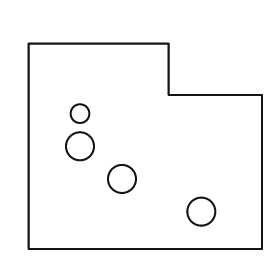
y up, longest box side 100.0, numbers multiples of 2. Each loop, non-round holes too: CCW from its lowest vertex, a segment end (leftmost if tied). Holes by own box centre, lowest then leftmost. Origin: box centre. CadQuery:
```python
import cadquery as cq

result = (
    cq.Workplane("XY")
    .moveTo(-50.0, -44.0)
    .lineTo(50.0, -44.0)
    .lineTo(50.0, 22.0)
    .lineTo(10.0, 22.0)
    .lineTo(10.0, 44.0)
    .lineTo(-50.0, 44.0)
    .close()
    .moveTo(24.0, -28.0)
    .circle(6.0)
    .moveTo(-10.0, -14.0)
    .circle(6.0)
    .moveTo(-28.0, 0.0)
    .circle(6.0)
    .moveTo(-28.0, 14.0)
    .circle(4.0)
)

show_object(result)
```